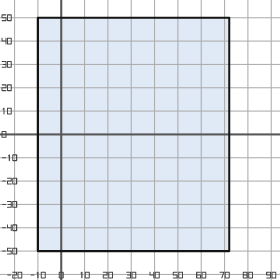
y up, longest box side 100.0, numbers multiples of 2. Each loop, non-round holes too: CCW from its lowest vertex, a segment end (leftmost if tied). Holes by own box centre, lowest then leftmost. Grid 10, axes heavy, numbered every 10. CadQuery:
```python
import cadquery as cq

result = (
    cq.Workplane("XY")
    .moveTo(-10.0, -50.0)
    .lineTo(72.0, -50.0)
    .lineTo(72.0, 50.0)
    .lineTo(-10.0, 50.0)
    .close()
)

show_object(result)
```